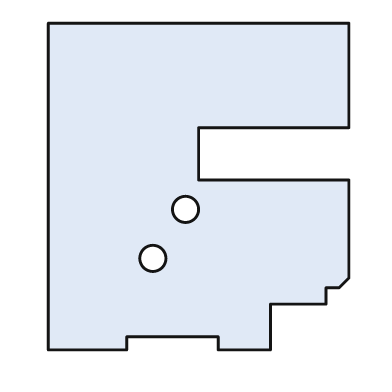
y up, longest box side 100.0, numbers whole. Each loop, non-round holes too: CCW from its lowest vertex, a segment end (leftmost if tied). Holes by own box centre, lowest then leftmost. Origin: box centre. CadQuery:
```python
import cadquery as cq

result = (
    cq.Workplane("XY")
    .moveTo(-46.0, -50.0)
    .lineTo(-22.0, -50.0)
    .lineTo(-22.0, -46.0)
    .lineTo(6.0, -46.0)
    .lineTo(6.0, -50.0)
    .lineTo(22.0, -50.0)
    .lineTo(22.0, -36.0)
    .lineTo(39.0, -36.0)
    .lineTo(39.0, -31.0)
    .lineTo(43.0, -31.0)
    .lineTo(46.0, -28.0)
    .lineTo(46.0, 2.0)
    .lineTo(0.0, 2.0)
    .lineTo(0.0, 18.0)
    .lineTo(46.0, 18.0)
    .lineTo(46.0, 50.0)
    .lineTo(-46.0, 50.0)
    .close()
    .moveTo(-14.0, -22.0)
    .circle(4.0)
    .moveTo(-4.0, -7.0)
    .circle(4.0)
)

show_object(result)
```